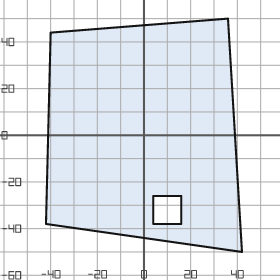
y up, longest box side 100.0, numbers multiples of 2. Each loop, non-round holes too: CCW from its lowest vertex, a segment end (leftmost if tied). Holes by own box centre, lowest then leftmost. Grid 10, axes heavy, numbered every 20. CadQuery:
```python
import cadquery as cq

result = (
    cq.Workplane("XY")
    .moveTo(42.0, -50.0)
    .lineTo(36.0, 50.0)
    .lineTo(-40.0, 44.0)
    .lineTo(-42.0, -38.0)
    .close()
    .moveTo(4.0, -38.0)
    .lineTo(16.0, -38.0)
    .lineTo(16.0, -26.0)
    .lineTo(4.0, -26.0)
    .close()
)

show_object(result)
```